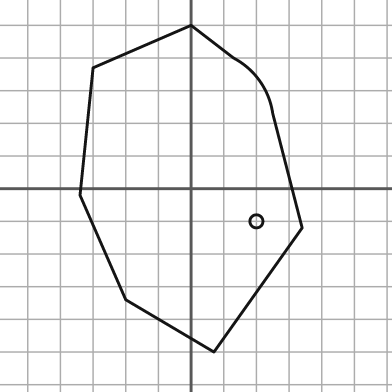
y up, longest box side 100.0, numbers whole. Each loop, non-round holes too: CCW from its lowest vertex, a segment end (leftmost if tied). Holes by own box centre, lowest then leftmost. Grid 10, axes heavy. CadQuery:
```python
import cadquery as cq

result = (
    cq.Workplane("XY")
    .moveTo(7.0, -50.0)
    .lineTo(34.0, -12.0)
    .lineTo(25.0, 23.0)
    .threePointArc((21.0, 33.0), (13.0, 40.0))
    .lineTo(0.0, 50.0)
    .lineTo(-30.0, 37.0)
    .lineTo(-34.0, -2.0)
    .lineTo(-20.0, -34.0)
    .close()
    .moveTo(20.0, -10.0)
    .circle(2.0)
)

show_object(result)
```